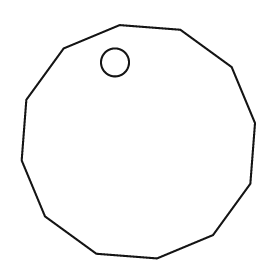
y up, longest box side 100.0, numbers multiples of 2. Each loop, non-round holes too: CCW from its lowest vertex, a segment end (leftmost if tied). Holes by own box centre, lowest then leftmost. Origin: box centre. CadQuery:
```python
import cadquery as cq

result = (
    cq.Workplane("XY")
    .moveTo(8.0, -50.0)
    .lineTo(32.0, -40.0)
    .lineTo(48.0, -18.0)
    .lineTo(50.0, 8.0)
    .lineTo(40.0, 32.0)
    .lineTo(18.0, 48.0)
    .lineTo(-8.0, 50.0)
    .lineTo(-32.0, 40.0)
    .lineTo(-48.0, 18.0)
    .lineTo(-50.0, -8.0)
    .lineTo(-40.0, -32.0)
    .lineTo(-18.0, -48.0)
    .close()
    .moveTo(-10.0, 34.0)
    .circle(6.0)
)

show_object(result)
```